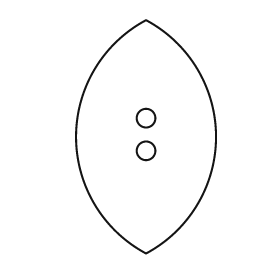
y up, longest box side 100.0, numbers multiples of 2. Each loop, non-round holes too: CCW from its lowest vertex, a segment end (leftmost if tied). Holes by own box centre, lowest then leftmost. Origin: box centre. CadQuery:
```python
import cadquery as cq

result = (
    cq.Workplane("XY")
    .moveTo(0.0, -50.0)
    .threePointArc((30.0, 0.0), (0.0, 50.0))
    .threePointArc((-30.0, 0.0), (0.0, -50.0))
    .close()
    .moveTo(0.0, -6.0)
    .circle(4.0)
    .moveTo(0.0, 8.0)
    .circle(4.0)
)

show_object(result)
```